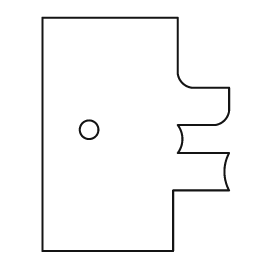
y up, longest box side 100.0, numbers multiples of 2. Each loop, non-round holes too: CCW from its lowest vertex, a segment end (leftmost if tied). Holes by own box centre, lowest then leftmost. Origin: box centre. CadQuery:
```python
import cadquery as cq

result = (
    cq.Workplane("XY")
    .moveTo(-40.0, -50.0)
    .lineTo(16.0, -50.0)
    .lineTo(16.0, -24.0)
    .lineTo(40.0, -24.0)
    .threePointArc((38.0, -16.0), (40.0, -8.0))
    .lineTo(18.0, -8.0)
    .threePointArc((20.0, -2.0), (18.0, 4.0))
    .lineTo(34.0, 4.0)
    .threePointArc((38.0, 6.0), (40.0, 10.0))
    .lineTo(40.0, 20.0)
    .lineTo(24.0, 20.0)
    .threePointArc((20.0, 22.0), (18.0, 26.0))
    .lineTo(18.0, 50.0)
    .lineTo(-40.0, 50.0)
    .close()
    .moveTo(-20.0, 2.0)
    .circle(4.0)
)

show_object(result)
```